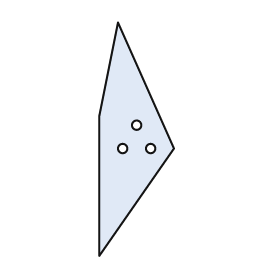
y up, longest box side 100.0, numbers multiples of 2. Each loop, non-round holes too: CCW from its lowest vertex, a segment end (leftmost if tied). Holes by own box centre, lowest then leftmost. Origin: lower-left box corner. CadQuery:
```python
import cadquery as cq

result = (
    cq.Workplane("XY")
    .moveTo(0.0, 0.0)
    .lineTo(32.0, 46.0)
    .lineTo(8.0, 100.0)
    .lineTo(0.0, 60.0)
    .close()
    .moveTo(10.0, 46.0)
    .circle(2.0)
    .moveTo(22.0, 46.0)
    .circle(2.0)
    .moveTo(16.0, 56.0)
    .circle(2.0)
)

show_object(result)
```